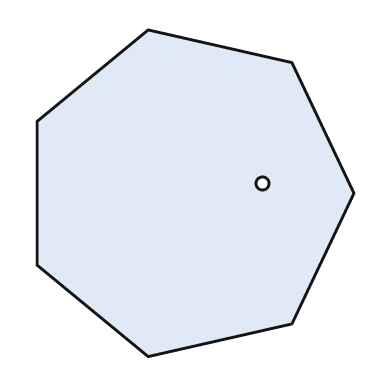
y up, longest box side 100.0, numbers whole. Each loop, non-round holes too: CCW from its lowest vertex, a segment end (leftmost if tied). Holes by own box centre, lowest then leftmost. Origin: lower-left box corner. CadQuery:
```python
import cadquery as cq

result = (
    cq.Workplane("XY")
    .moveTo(34.0, 0.0)
    .lineTo(78.0, 10.0)
    .lineTo(97.0, 50.0)
    .lineTo(78.0, 90.0)
    .lineTo(34.0, 100.0)
    .lineTo(0.0, 72.0)
    .lineTo(0.0, 28.0)
    .close()
    .moveTo(69.0, 53.0)
    .circle(2.0)
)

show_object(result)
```